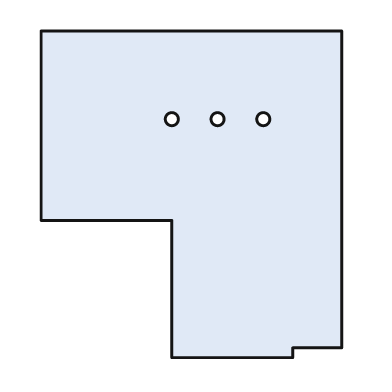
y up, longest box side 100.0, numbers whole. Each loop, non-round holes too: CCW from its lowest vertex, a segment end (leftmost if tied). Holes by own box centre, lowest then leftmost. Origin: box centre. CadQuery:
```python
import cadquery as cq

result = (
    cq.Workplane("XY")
    .moveTo(-6.0, -50.0)
    .lineTo(31.0, -50.0)
    .lineTo(31.0, -47.0)
    .lineTo(46.0, -47.0)
    .lineTo(46.0, 50.0)
    .lineTo(-46.0, 50.0)
    .lineTo(-46.0, -8.0)
    .lineTo(-6.0, -8.0)
    .close()
    .moveTo(-6.0, 23.0)
    .circle(2.0)
    .moveTo(8.0, 23.0)
    .circle(2.0)
    .moveTo(22.0, 23.0)
    .circle(2.0)
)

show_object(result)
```